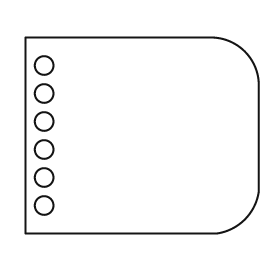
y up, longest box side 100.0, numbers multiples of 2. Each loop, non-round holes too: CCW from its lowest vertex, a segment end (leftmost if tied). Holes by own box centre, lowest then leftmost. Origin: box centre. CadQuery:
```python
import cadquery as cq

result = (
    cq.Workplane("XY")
    .moveTo(-50.0, -42.0)
    .lineTo(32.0, -42.0)
    .threePointArc((44.0, -36.0), (50.0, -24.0))
    .lineTo(50.0, 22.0)
    .threePointArc((44.0, 36.0), (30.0, 42.0))
    .lineTo(-50.0, 42.0)
    .close()
    .moveTo(-42.0, -30.0)
    .circle(4.0)
    .moveTo(-42.0, -18.0)
    .circle(4.0)
    .moveTo(-42.0, -6.0)
    .circle(4.0)
    .moveTo(-42.0, 6.0)
    .circle(4.0)
    .moveTo(-42.0, 18.0)
    .circle(4.0)
    .moveTo(-42.0, 30.0)
    .circle(4.0)
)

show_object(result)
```